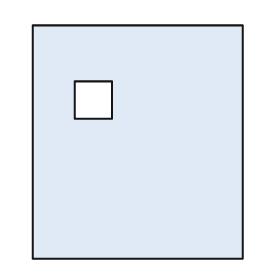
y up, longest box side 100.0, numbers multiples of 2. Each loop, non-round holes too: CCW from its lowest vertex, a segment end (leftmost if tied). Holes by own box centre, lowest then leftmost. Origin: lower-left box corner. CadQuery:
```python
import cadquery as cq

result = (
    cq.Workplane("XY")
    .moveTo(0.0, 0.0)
    .lineTo(90.0, 0.0)
    .lineTo(90.0, 100.0)
    .lineTo(0.0, 100.0)
    .close()
    .moveTo(18.0, 60.0)
    .lineTo(34.0, 60.0)
    .lineTo(34.0, 76.0)
    .lineTo(18.0, 76.0)
    .close()
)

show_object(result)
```